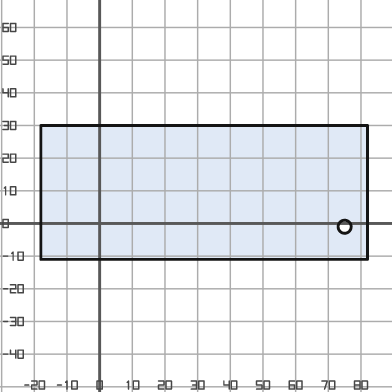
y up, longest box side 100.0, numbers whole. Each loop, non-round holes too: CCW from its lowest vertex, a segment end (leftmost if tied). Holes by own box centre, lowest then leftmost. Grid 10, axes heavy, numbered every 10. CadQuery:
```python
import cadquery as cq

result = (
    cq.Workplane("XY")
    .moveTo(-18.0, -11.0)
    .lineTo(82.0, -11.0)
    .lineTo(82.0, 30.0)
    .lineTo(-18.0, 30.0)
    .close()
    .moveTo(75.0, -1.0)
    .circle(2.0)
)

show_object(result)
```